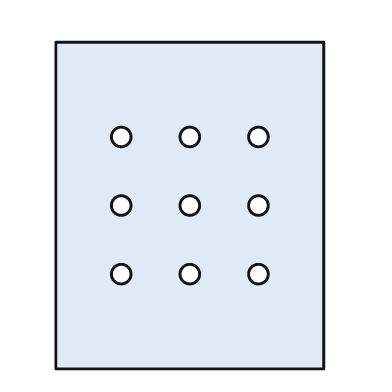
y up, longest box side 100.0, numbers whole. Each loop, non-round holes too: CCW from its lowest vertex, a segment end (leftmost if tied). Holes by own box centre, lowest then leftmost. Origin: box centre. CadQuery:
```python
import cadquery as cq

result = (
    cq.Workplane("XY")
    .moveTo(-41.0, -50.0)
    .lineTo(41.0, -50.0)
    .lineTo(41.0, 50.0)
    .lineTo(-41.0, 50.0)
    .close()
    .moveTo(-21.0, -21.0)
    .circle(3.0)
    .moveTo(0.0, -21.0)
    .circle(3.0)
    .moveTo(21.0, -21.0)
    .circle(3.0)
    .moveTo(-21.0, 0.0)
    .circle(3.0)
    .moveTo(0.0, 0.0)
    .circle(3.0)
    .moveTo(21.0, 0.0)
    .circle(3.0)
    .moveTo(-21.0, 21.0)
    .circle(3.0)
    .moveTo(0.0, 21.0)
    .circle(3.0)
    .moveTo(21.0, 21.0)
    .circle(3.0)
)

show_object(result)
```